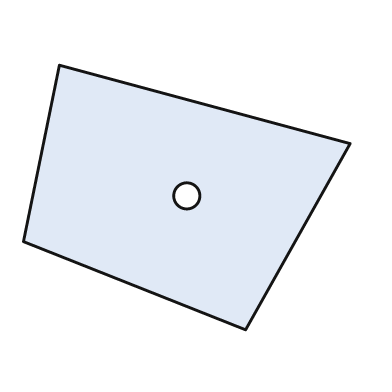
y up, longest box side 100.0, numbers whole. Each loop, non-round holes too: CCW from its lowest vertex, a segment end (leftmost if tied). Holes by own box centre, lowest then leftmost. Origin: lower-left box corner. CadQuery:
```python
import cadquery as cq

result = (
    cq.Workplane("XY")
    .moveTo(68.0, 0.0)
    .lineTo(100.0, 57.0)
    .lineTo(11.0, 81.0)
    .lineTo(0.0, 27.0)
    .close()
    .moveTo(50.0, 41.0)
    .circle(4.0)
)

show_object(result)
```